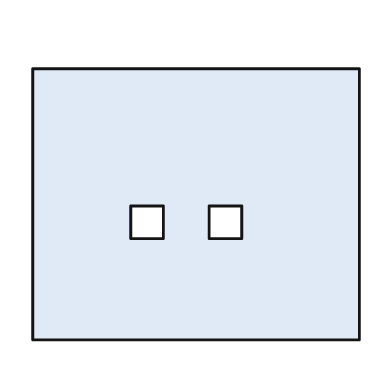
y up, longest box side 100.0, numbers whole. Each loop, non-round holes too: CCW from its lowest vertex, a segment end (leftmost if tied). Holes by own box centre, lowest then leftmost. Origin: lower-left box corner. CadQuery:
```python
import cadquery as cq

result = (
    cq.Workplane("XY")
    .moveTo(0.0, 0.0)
    .lineTo(100.0, 0.0)
    .lineTo(100.0, 83.0)
    .lineTo(0.0, 83.0)
    .close()
    .moveTo(30.0, 31.0)
    .lineTo(40.0, 31.0)
    .lineTo(40.0, 41.0)
    .lineTo(30.0, 41.0)
    .close()
    .moveTo(54.0, 31.0)
    .lineTo(64.0, 31.0)
    .lineTo(64.0, 41.0)
    .lineTo(54.0, 41.0)
    .close()
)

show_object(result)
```